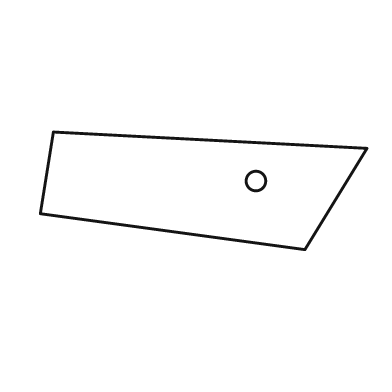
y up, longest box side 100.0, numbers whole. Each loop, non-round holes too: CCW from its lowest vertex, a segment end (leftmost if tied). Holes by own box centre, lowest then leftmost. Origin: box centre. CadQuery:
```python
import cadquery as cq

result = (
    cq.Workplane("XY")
    .moveTo(31.0, -18.0)
    .lineTo(50.0, 13.0)
    .lineTo(-46.0, 18.0)
    .lineTo(-50.0, -7.0)
    .close()
    .moveTo(16.0, 3.0)
    .circle(3.0)
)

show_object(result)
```